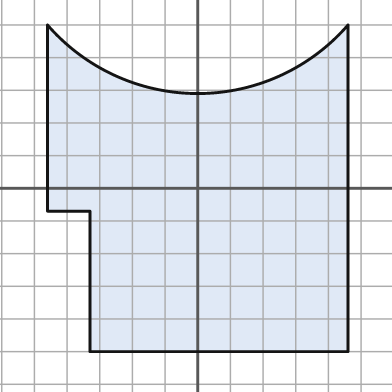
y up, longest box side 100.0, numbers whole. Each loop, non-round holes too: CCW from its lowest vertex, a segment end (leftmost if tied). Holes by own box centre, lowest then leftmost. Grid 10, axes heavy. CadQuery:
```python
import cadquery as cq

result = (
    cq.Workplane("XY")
    .moveTo(-33.0, -50.0)
    .lineTo(46.0, -50.0)
    .lineTo(46.0, 50.0)
    .threePointArc((0.0, 29.0), (-46.0, 50.0))
    .lineTo(-46.0, -7.0)
    .lineTo(-33.0, -7.0)
    .close()
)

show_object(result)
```